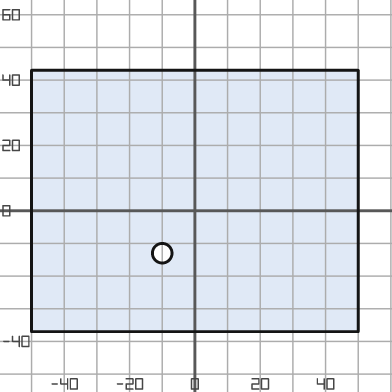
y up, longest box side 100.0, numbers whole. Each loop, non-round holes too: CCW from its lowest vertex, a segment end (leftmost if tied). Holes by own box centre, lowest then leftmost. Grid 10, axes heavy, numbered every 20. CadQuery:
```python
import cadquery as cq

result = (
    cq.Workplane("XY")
    .moveTo(-50.0, -37.0)
    .lineTo(50.0, -37.0)
    .lineTo(50.0, 43.0)
    .lineTo(-50.0, 43.0)
    .close()
    .moveTo(-10.0, -13.0)
    .circle(3.0)
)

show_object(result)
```